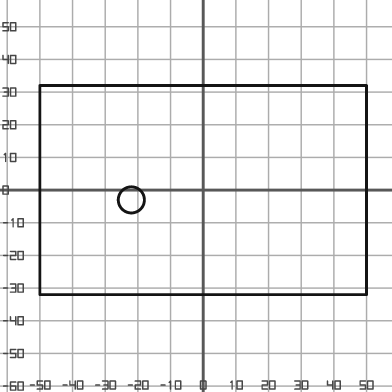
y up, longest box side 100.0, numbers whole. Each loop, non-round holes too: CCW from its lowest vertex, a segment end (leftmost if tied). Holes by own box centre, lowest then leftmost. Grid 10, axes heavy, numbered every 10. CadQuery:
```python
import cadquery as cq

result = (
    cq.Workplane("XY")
    .moveTo(-50.0, -32.0)
    .lineTo(50.0, -32.0)
    .lineTo(50.0, 32.0)
    .lineTo(-50.0, 32.0)
    .close()
    .moveTo(-22.0, -3.0)
    .circle(4.0)
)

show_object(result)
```